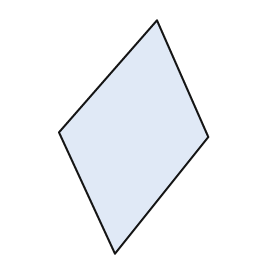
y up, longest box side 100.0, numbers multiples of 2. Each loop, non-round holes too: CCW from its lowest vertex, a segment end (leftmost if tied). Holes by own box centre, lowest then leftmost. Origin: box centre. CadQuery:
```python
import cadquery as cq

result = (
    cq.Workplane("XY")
    .moveTo(-8.0, -50.0)
    .lineTo(32.0, 0.0)
    .lineTo(10.0, 50.0)
    .lineTo(-32.0, 2.0)
    .close()
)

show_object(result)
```